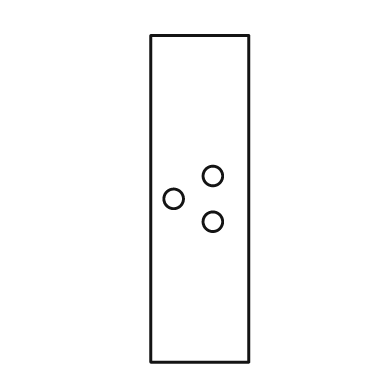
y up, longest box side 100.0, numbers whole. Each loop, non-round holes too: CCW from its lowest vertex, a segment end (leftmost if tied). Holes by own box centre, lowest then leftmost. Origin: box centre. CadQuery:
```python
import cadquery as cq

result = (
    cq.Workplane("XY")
    .moveTo(-15.0, -50.0)
    .lineTo(15.0, -50.0)
    .lineTo(15.0, 50.0)
    .lineTo(-15.0, 50.0)
    .close()
    .moveTo(4.0, -7.0)
    .circle(3.0)
    .moveTo(-8.0, 0.0)
    .circle(3.0)
    .moveTo(4.0, 7.0)
    .circle(3.0)
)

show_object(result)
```